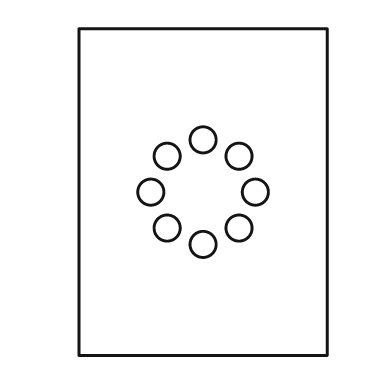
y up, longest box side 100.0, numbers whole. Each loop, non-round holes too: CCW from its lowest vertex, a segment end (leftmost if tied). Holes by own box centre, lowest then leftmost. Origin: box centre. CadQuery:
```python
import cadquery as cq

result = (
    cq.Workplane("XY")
    .moveTo(-38.0, -50.0)
    .lineTo(38.0, -50.0)
    .lineTo(38.0, 50.0)
    .lineTo(-38.0, 50.0)
    .close()
    .moveTo(0.0, -16.0)
    .circle(4.0)
    .moveTo(-11.0, -11.0)
    .circle(4.0)
    .moveTo(11.0, -11.0)
    .circle(4.0)
    .moveTo(-16.0, 0.0)
    .circle(4.0)
    .moveTo(16.0, 0.0)
    .circle(4.0)
    .moveTo(-11.0, 11.0)
    .circle(4.0)
    .moveTo(11.0, 11.0)
    .circle(4.0)
    .moveTo(0.0, 16.0)
    .circle(4.0)
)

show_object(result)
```